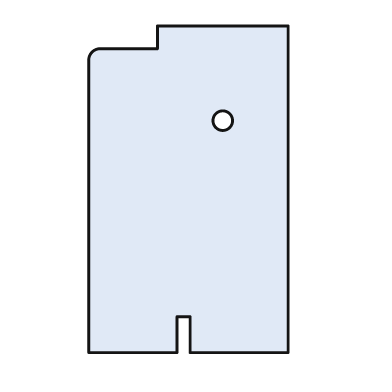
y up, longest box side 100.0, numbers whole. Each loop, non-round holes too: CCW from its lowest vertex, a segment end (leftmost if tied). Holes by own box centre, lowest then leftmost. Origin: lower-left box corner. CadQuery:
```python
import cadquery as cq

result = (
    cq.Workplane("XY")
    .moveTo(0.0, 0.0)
    .lineTo(27.0, 0.0)
    .lineTo(27.0, 11.0)
    .lineTo(31.0, 11.0)
    .lineTo(31.0, 0.0)
    .lineTo(61.0, 0.0)
    .lineTo(61.0, 100.0)
    .lineTo(21.0, 100.0)
    .lineTo(21.0, 93.0)
    .lineTo(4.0, 93.0)
    .threePointArc((1.0, 92.0), (0.0, 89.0))
    .close()
    .moveTo(41.0, 71.0)
    .circle(3.0)
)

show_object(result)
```